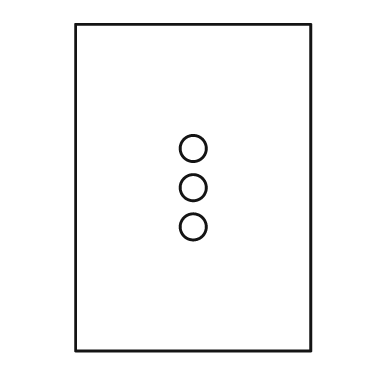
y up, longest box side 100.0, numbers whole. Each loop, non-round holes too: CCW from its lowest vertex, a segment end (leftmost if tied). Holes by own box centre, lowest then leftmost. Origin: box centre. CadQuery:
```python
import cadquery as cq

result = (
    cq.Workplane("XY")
    .moveTo(-36.0, -50.0)
    .lineTo(36.0, -50.0)
    .lineTo(36.0, 50.0)
    .lineTo(-36.0, 50.0)
    .close()
    .moveTo(0.0, -12.0)
    .circle(4.0)
    .moveTo(0.0, 0.0)
    .circle(4.0)
    .moveTo(0.0, 12.0)
    .circle(4.0)
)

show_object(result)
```